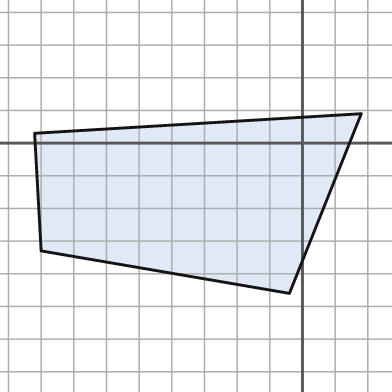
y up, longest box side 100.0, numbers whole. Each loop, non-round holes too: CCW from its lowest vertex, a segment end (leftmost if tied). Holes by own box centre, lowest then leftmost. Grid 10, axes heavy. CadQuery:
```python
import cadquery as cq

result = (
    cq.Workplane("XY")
    .moveTo(-4.0, -46.0)
    .lineTo(18.0, 9.0)
    .lineTo(-82.0, 3.0)
    .lineTo(-80.0, -33.0)
    .close()
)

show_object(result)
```